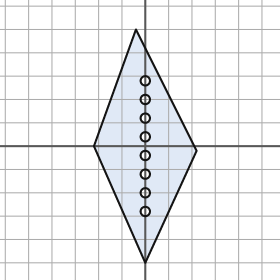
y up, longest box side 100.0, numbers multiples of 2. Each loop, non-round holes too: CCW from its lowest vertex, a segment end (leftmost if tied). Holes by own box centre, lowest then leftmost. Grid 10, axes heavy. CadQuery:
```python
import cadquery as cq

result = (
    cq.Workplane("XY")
    .moveTo(0.0, -50.0)
    .lineTo(22.0, -2.0)
    .lineTo(-4.0, 50.0)
    .lineTo(-22.0, 0.0)
    .close()
    .moveTo(0.0, -28.0)
    .circle(2.0)
    .moveTo(0.0, -20.0)
    .circle(2.0)
    .moveTo(0.0, -12.0)
    .circle(2.0)
    .moveTo(0.0, -4.0)
    .circle(2.0)
    .moveTo(0.0, 4.0)
    .circle(2.0)
    .moveTo(0.0, 12.0)
    .circle(2.0)
    .moveTo(0.0, 20.0)
    .circle(2.0)
    .moveTo(0.0, 28.0)
    .circle(2.0)
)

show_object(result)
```